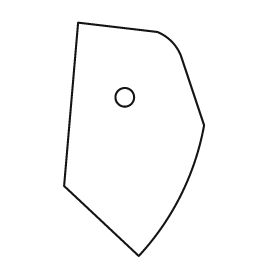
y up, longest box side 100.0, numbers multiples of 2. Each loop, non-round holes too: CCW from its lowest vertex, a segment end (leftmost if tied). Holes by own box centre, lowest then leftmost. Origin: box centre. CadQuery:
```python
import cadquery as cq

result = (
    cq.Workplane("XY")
    .moveTo(2.0, -50.0)
    .threePointArc((20.0, -24.0), (30.0, 6.0))
    .lineTo(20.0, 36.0)
    .threePointArc((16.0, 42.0), (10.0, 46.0))
    .lineTo(-24.0, 50.0)
    .lineTo(-30.0, -20.0)
    .close()
    .moveTo(-4.0, 18.0)
    .circle(4.0)
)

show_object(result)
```